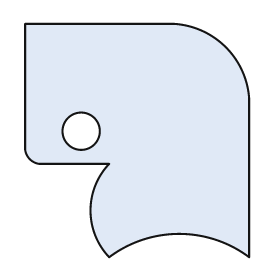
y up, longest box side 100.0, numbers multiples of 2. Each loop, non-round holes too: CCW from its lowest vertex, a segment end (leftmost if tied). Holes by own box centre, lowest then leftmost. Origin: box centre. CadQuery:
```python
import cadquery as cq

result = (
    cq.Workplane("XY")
    .moveTo(-12.0, -50.0)
    .threePointArc((18.0, -40.0), (48.0, -50.0))
    .lineTo(48.0, 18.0)
    .threePointArc((38.0, 40.0), (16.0, 50.0))
    .lineTo(-48.0, 50.0)
    .lineTo(-48.0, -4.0)
    .threePointArc((-46.0, -8.0), (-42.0, -10.0))
    .lineTo(-12.0, -10.0)
    .threePointArc((-20.0, -30.0), (-12.0, -50.0))
    .close()
    .moveTo(-24.0, 4.0)
    .circle(8.0)
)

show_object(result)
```